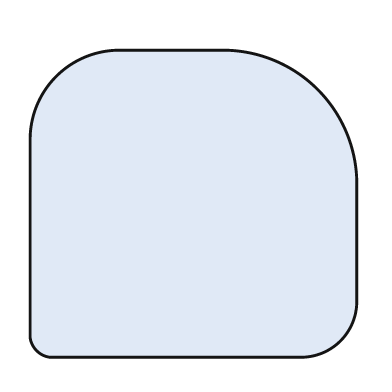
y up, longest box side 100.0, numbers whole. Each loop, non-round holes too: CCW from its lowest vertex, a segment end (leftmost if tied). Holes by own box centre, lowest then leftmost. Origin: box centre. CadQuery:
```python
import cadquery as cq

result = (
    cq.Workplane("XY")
    .moveTo(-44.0, -47.0)
    .lineTo(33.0, -47.0)
    .threePointArc((45.0, -42.0), (50.0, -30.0))
    .lineTo(50.0, 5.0)
    .threePointArc((38.0, 35.0), (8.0, 47.0))
    .lineTo(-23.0, 47.0)
    .threePointArc((-42.0, 39.0), (-50.0, 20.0))
    .lineTo(-50.0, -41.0)
    .threePointArc((-48.0, -45.0), (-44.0, -47.0))
    .close()
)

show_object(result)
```